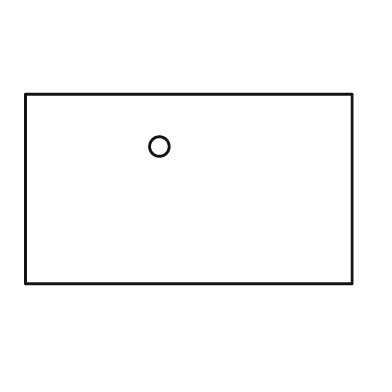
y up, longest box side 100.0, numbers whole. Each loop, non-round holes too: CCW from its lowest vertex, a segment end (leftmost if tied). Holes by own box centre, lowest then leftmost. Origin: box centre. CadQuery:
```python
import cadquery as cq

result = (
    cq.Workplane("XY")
    .moveTo(-50.0, -29.0)
    .lineTo(50.0, -29.0)
    .lineTo(50.0, 29.0)
    .lineTo(-50.0, 29.0)
    .close()
    .moveTo(-9.0, 13.0)
    .circle(3.0)
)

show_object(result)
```